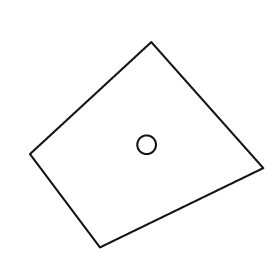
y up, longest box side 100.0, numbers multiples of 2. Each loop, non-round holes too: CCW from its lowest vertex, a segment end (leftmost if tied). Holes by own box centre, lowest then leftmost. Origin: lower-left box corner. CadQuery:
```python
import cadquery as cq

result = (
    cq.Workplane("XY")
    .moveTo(30.0, 0.0)
    .lineTo(100.0, 34.0)
    .lineTo(52.0, 88.0)
    .lineTo(0.0, 40.0)
    .close()
    .moveTo(50.0, 44.0)
    .circle(4.0)
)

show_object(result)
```